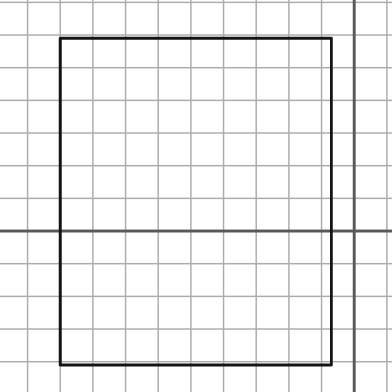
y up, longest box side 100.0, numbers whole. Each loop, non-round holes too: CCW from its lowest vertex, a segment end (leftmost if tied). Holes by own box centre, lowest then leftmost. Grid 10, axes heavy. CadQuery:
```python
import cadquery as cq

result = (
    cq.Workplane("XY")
    .moveTo(-90.0, -41.0)
    .lineTo(-7.0, -41.0)
    .lineTo(-7.0, 59.0)
    .lineTo(-90.0, 59.0)
    .close()
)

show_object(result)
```